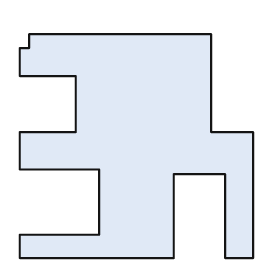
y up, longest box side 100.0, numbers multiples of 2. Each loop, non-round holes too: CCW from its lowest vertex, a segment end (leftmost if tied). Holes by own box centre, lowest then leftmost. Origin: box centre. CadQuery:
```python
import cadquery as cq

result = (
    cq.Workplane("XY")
    .moveTo(-50.0, -48.0)
    .lineTo(16.0, -48.0)
    .lineTo(16.0, -12.0)
    .lineTo(38.0, -12.0)
    .lineTo(38.0, -48.0)
    .lineTo(50.0, -48.0)
    .lineTo(50.0, 6.0)
    .lineTo(32.0, 6.0)
    .lineTo(32.0, 48.0)
    .lineTo(-46.0, 48.0)
    .lineTo(-46.0, 42.0)
    .lineTo(-50.0, 42.0)
    .lineTo(-50.0, 30.0)
    .lineTo(-26.0, 30.0)
    .lineTo(-26.0, 6.0)
    .lineTo(-50.0, 6.0)
    .lineTo(-50.0, -10.0)
    .lineTo(-16.0, -10.0)
    .lineTo(-16.0, -38.0)
    .lineTo(-50.0, -38.0)
    .close()
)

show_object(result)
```